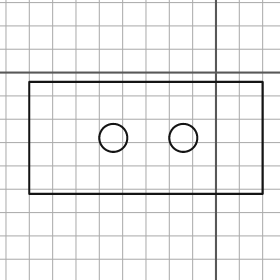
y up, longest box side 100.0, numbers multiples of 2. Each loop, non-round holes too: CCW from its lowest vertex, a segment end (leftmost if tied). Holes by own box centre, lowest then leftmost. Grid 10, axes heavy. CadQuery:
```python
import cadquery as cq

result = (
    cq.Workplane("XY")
    .moveTo(-80.0, -52.0)
    .lineTo(20.0, -52.0)
    .lineTo(20.0, -4.0)
    .lineTo(-80.0, -4.0)
    .close()
    .moveTo(-44.0, -28.0)
    .circle(6.0)
    .moveTo(-14.0, -28.0)
    .circle(6.0)
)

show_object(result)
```